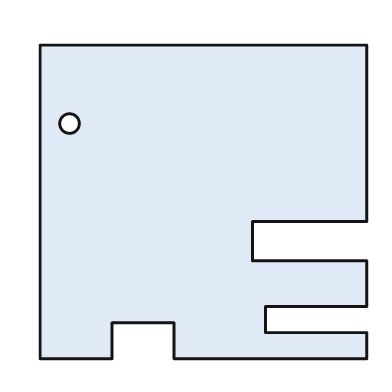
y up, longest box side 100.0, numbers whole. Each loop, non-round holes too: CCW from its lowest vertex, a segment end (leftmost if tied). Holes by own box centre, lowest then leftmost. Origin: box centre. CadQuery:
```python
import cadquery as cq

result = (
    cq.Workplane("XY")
    .moveTo(-50.0, -48.0)
    .lineTo(-28.0, -48.0)
    .lineTo(-28.0, -37.0)
    .lineTo(-9.0, -37.0)
    .lineTo(-9.0, -48.0)
    .lineTo(50.0, -48.0)
    .lineTo(50.0, -40.0)
    .lineTo(19.0, -40.0)
    .lineTo(19.0, -32.0)
    .lineTo(50.0, -32.0)
    .lineTo(50.0, -18.0)
    .lineTo(15.0, -18.0)
    .lineTo(15.0, -6.0)
    .lineTo(50.0, -6.0)
    .lineTo(50.0, 48.0)
    .lineTo(-50.0, 48.0)
    .close()
    .moveTo(-41.0, 24.0)
    .circle(3.0)
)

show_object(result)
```